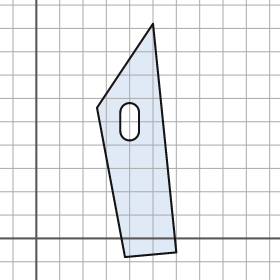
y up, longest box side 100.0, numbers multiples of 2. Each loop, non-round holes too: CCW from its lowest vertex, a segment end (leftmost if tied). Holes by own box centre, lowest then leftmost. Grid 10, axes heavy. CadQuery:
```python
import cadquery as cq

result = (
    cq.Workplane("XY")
    .moveTo(38.0, -8.0)
    .lineTo(60.0, -6.0)
    .lineTo(50.0, 92.0)
    .lineTo(26.0, 56.0)
    .close()
    .moveTo(36.0, 46.0)
    .threePointArc((40.0, 42.0), (44.0, 46.0))
    .lineTo(44.0, 54.0)
    .threePointArc((40.0, 58.0), (36.0, 54.0))
    .close()
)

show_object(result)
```